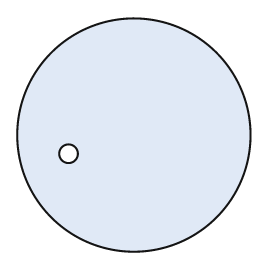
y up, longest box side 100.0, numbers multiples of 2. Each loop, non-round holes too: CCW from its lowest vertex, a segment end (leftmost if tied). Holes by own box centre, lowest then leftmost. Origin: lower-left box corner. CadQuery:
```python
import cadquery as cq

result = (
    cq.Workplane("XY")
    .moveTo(50.0, 50.0)
    .circle(50.0)
    .moveTo(22.0, 42.0)
    .circle(4.0)
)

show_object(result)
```